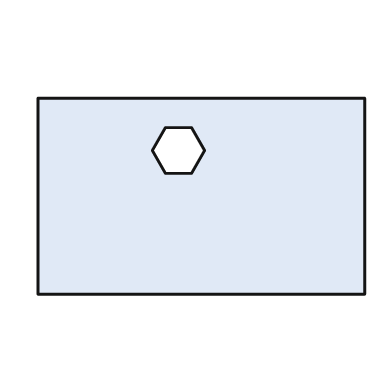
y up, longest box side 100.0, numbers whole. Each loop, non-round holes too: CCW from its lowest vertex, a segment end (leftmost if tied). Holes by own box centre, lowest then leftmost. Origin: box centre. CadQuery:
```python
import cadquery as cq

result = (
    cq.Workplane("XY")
    .moveTo(-50.0, -30.0)
    .lineTo(50.0, -30.0)
    .lineTo(50.0, 30.0)
    .lineTo(-50.0, 30.0)
    .close()
    .moveTo(-11.0, 7.0)
    .lineTo(-3.0, 7.0)
    .lineTo(1.0, 14.0)
    .lineTo(-3.0, 21.0)
    .lineTo(-11.0, 21.0)
    .lineTo(-15.0, 14.0)
    .close()
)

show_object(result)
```